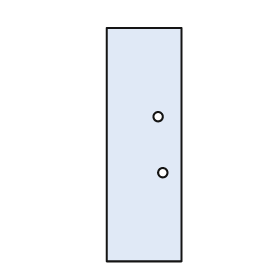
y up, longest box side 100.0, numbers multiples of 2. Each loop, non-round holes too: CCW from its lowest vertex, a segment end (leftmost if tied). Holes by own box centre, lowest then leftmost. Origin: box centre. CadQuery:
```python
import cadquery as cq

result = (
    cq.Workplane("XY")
    .moveTo(-16.0, -50.0)
    .lineTo(16.0, -50.0)
    .lineTo(16.0, 50.0)
    .lineTo(-16.0, 50.0)
    .close()
    .moveTo(8.0, -12.0)
    .circle(2.0)
    .moveTo(6.0, 12.0)
    .circle(2.0)
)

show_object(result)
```